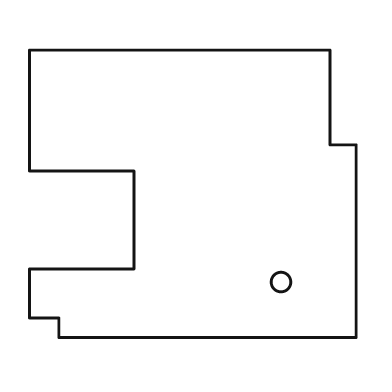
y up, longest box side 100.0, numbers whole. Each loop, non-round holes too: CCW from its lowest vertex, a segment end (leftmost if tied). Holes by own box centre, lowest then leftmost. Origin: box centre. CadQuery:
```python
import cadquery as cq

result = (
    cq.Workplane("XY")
    .moveTo(-41.0, -44.0)
    .lineTo(50.0, -44.0)
    .lineTo(50.0, 15.0)
    .lineTo(42.0, 15.0)
    .lineTo(42.0, 44.0)
    .lineTo(-50.0, 44.0)
    .lineTo(-50.0, 7.0)
    .lineTo(-18.0, 7.0)
    .lineTo(-18.0, -23.0)
    .lineTo(-50.0, -23.0)
    .lineTo(-50.0, -38.0)
    .lineTo(-41.0, -38.0)
    .close()
    .moveTo(27.0, -27.0)
    .circle(3.0)
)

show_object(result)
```